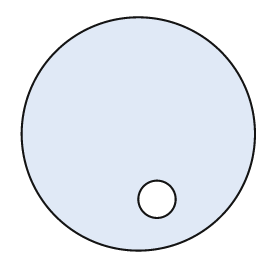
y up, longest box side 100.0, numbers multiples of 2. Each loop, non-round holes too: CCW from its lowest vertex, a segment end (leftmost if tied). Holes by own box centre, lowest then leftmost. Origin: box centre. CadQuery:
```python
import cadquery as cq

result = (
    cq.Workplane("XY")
    .moveTo(0.0, 0.0)
    .circle(50.0)
    .moveTo(8.0, -28.0)
    .circle(8.0)
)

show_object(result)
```